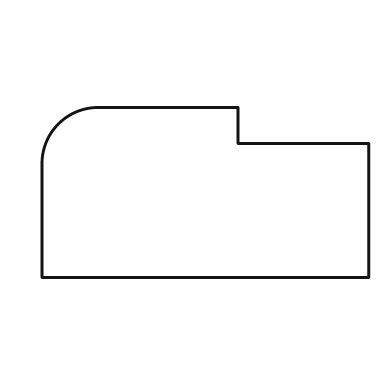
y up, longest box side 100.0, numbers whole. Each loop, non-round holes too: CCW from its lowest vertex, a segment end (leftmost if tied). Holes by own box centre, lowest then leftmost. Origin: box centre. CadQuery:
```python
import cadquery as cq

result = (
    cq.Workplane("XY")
    .moveTo(-50.0, -26.0)
    .lineTo(50.0, -26.0)
    .lineTo(50.0, 15.0)
    .lineTo(10.0, 15.0)
    .lineTo(10.0, 26.0)
    .lineTo(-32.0, 26.0)
    .threePointArc((-45.0, 21.0), (-50.0, 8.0))
    .close()
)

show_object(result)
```